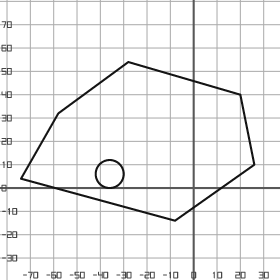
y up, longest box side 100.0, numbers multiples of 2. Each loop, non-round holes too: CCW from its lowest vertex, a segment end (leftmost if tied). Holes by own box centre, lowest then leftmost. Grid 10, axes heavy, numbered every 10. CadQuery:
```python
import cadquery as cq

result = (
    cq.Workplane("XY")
    .moveTo(-8.0, -14.0)
    .lineTo(26.0, 10.0)
    .lineTo(20.0, 40.0)
    .lineTo(-28.0, 54.0)
    .lineTo(-58.0, 32.0)
    .lineTo(-74.0, 4.0)
    .close()
    .moveTo(-36.0, 6.0)
    .circle(6.0)
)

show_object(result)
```